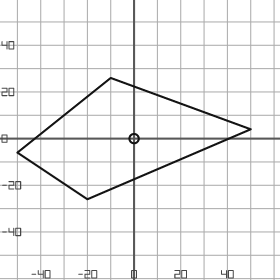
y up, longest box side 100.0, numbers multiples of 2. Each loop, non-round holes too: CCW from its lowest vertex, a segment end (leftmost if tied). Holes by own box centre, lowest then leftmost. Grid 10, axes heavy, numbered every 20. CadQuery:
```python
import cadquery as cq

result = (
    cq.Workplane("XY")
    .moveTo(-20.0, -26.0)
    .lineTo(50.0, 4.0)
    .lineTo(-10.0, 26.0)
    .lineTo(-50.0, -6.0)
    .close()
    .moveTo(0.0, 0.0)
    .circle(2.0)
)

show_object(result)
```